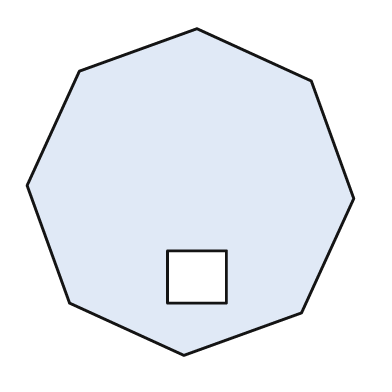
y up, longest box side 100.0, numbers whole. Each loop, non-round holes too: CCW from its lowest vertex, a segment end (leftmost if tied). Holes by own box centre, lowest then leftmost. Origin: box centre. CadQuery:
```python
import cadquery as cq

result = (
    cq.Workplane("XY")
    .moveTo(-2.0, -50.0)
    .lineTo(34.0, -37.0)
    .lineTo(50.0, -2.0)
    .lineTo(37.0, 34.0)
    .lineTo(2.0, 50.0)
    .lineTo(-34.0, 37.0)
    .lineTo(-50.0, 2.0)
    .lineTo(-37.0, -34.0)
    .close()
    .moveTo(-7.0, -34.0)
    .lineTo(11.0, -34.0)
    .lineTo(11.0, -18.0)
    .lineTo(-7.0, -18.0)
    .close()
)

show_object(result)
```